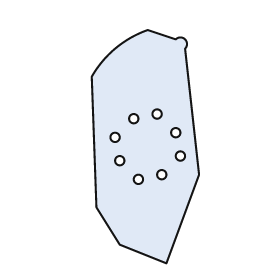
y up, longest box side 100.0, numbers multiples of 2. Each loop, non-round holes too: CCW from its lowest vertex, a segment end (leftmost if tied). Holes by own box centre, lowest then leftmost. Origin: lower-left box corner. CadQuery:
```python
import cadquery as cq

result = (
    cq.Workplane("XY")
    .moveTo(32.0, 0.0)
    .lineTo(46.0, 38.0)
    .lineTo(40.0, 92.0)
    .threePointArc((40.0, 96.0), (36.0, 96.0))
    .lineTo(24.0, 100.0)
    .threePointArc((10.0, 92.0), (0.0, 80.0))
    .lineTo(2.0, 24.0)
    .lineTo(12.0, 8.0)
    .close()
    .moveTo(20.0, 36.0)
    .circle(2.0)
    .moveTo(30.0, 38.0)
    .circle(2.0)
    .moveTo(12.0, 44.0)
    .circle(2.0)
    .moveTo(38.0, 46.0)
    .circle(2.0)
    .moveTo(10.0, 54.0)
    .circle(2.0)
    .moveTo(36.0, 56.0)
    .circle(2.0)
    .moveTo(18.0, 62.0)
    .circle(2.0)
    .moveTo(28.0, 64.0)
    .circle(2.0)
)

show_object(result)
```